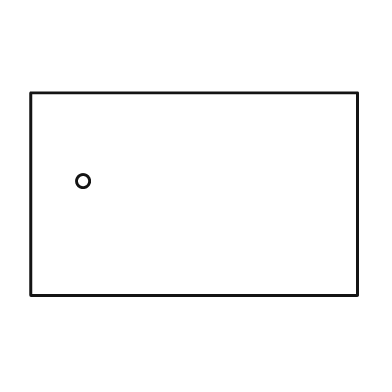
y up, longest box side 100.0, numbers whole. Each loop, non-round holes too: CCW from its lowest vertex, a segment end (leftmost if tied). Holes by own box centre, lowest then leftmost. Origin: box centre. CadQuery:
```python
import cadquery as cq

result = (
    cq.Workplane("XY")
    .moveTo(-50.0, -31.0)
    .lineTo(50.0, -31.0)
    .lineTo(50.0, 31.0)
    .lineTo(-50.0, 31.0)
    .close()
    .moveTo(-34.0, 4.0)
    .circle(2.0)
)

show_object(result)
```